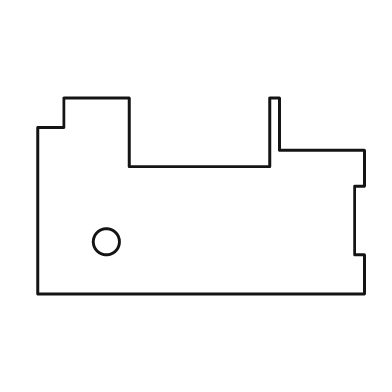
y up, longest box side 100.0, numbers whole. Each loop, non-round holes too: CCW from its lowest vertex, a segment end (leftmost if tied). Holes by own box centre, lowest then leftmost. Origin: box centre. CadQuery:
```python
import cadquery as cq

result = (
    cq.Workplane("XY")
    .moveTo(-50.0, -30.0)
    .lineTo(50.0, -30.0)
    .lineTo(50.0, -18.0)
    .lineTo(47.0, -18.0)
    .lineTo(47.0, 3.0)
    .lineTo(50.0, 3.0)
    .lineTo(50.0, 14.0)
    .lineTo(24.0, 14.0)
    .lineTo(24.0, 30.0)
    .lineTo(21.0, 30.0)
    .lineTo(21.0, 9.0)
    .lineTo(-22.0, 9.0)
    .lineTo(-22.0, 30.0)
    .lineTo(-42.0, 30.0)
    .lineTo(-42.0, 21.0)
    .lineTo(-50.0, 21.0)
    .close()
    .moveTo(-29.0, -14.0)
    .circle(4.0)
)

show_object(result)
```